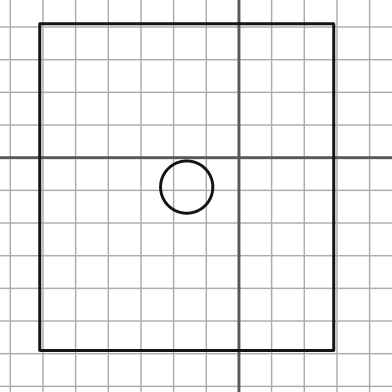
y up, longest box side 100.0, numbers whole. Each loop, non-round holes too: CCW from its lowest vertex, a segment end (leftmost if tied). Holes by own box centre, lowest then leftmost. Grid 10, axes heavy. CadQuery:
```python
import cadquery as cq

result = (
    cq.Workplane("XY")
    .moveTo(-61.0, -59.0)
    .lineTo(29.0, -59.0)
    .lineTo(29.0, 41.0)
    .lineTo(-61.0, 41.0)
    .close()
    .moveTo(-16.0, -9.0)
    .circle(8.0)
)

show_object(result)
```